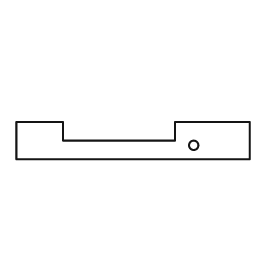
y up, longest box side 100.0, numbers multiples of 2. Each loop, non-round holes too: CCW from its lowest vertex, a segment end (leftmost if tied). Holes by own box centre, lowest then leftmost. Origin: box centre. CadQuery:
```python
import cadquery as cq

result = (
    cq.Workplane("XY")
    .moveTo(-50.0, -8.0)
    .lineTo(50.0, -8.0)
    .lineTo(50.0, 8.0)
    .lineTo(18.0, 8.0)
    .lineTo(18.0, 0.0)
    .lineTo(-30.0, 0.0)
    .lineTo(-30.0, 8.0)
    .lineTo(-50.0, 8.0)
    .close()
    .moveTo(26.0, -2.0)
    .circle(2.0)
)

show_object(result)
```